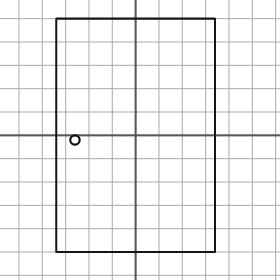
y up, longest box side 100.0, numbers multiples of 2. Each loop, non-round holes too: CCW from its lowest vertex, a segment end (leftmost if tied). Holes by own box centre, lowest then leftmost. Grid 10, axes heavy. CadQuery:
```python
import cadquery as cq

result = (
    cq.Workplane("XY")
    .moveTo(-34.0, -50.0)
    .lineTo(34.0, -50.0)
    .lineTo(34.0, 50.0)
    .lineTo(-34.0, 50.0)
    .close()
    .moveTo(-26.0, -2.0)
    .circle(2.0)
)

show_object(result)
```